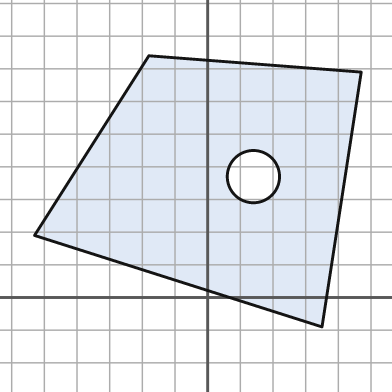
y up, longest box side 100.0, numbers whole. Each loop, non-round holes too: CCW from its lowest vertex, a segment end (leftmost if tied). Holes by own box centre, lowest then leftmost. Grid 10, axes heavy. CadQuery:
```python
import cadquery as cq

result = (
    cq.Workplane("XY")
    .moveTo(35.0, -9.0)
    .lineTo(47.0, 69.0)
    .lineTo(-18.0, 74.0)
    .lineTo(-53.0, 19.0)
    .close()
    .moveTo(14.0, 37.0)
    .circle(8.0)
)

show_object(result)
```